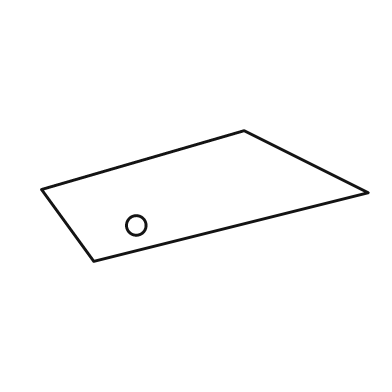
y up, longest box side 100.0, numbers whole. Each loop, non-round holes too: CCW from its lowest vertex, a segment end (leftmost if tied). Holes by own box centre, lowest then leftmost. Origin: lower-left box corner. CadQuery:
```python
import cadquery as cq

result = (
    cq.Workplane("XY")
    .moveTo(16.0, 0.0)
    .lineTo(100.0, 21.0)
    .lineTo(62.0, 40.0)
    .lineTo(0.0, 22.0)
    .close()
    .moveTo(29.0, 11.0)
    .circle(3.0)
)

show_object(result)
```